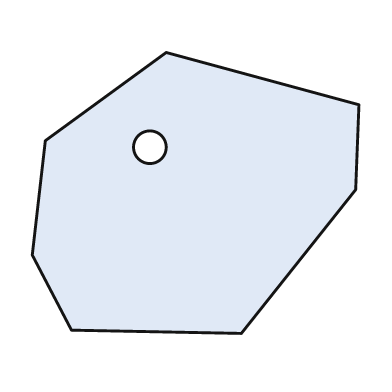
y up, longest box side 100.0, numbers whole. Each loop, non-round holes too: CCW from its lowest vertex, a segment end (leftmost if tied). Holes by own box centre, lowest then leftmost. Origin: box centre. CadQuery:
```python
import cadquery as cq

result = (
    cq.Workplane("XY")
    .moveTo(14.0, -43.0)
    .lineTo(49.0, 1.0)
    .lineTo(50.0, 27.0)
    .lineTo(-9.0, 43.0)
    .lineTo(-46.0, 16.0)
    .lineTo(-50.0, -19.0)
    .lineTo(-38.0, -42.0)
    .close()
    .moveTo(-14.0, 14.0)
    .circle(5.0)
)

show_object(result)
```